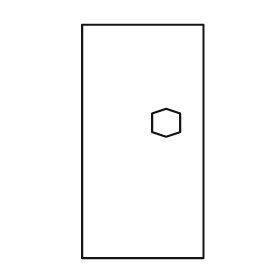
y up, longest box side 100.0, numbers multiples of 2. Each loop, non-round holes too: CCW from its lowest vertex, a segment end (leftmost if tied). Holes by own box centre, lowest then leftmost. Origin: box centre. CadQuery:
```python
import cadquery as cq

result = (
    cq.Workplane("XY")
    .moveTo(-26.0, -50.0)
    .lineTo(26.0, -50.0)
    .lineTo(26.0, 50.0)
    .lineTo(-26.0, 50.0)
    .close()
    .moveTo(10.0, 2.0)
    .lineTo(16.0, 4.0)
    .lineTo(16.0, 12.0)
    .lineTo(10.0, 14.0)
    .lineTo(4.0, 12.0)
    .lineTo(4.0, 4.0)
    .close()
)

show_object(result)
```